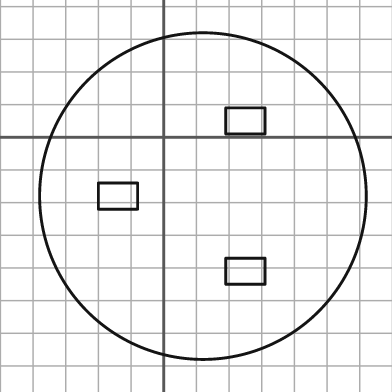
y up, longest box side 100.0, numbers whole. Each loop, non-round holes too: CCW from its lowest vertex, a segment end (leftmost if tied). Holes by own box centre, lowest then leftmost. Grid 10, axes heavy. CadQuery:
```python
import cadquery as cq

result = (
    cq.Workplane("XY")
    .moveTo(12.0, -18.0)
    .circle(50.0)
    .moveTo(19.0, -45.0)
    .lineTo(31.0, -45.0)
    .lineTo(31.0, -37.0)
    .lineTo(19.0, -37.0)
    .close()
    .moveTo(-20.0, -22.0)
    .lineTo(-8.0, -22.0)
    .lineTo(-8.0, -14.0)
    .lineTo(-20.0, -14.0)
    .close()
    .moveTo(19.0, 1.0)
    .lineTo(31.0, 1.0)
    .lineTo(31.0, 9.0)
    .lineTo(19.0, 9.0)
    .close()
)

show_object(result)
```